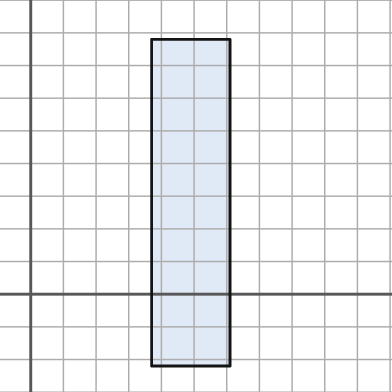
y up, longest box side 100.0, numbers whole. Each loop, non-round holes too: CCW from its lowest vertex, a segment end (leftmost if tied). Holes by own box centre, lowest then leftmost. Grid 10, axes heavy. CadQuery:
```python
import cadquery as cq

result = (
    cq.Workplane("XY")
    .moveTo(37.0, -22.0)
    .lineTo(61.0, -22.0)
    .lineTo(61.0, 78.0)
    .lineTo(37.0, 78.0)
    .close()
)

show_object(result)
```